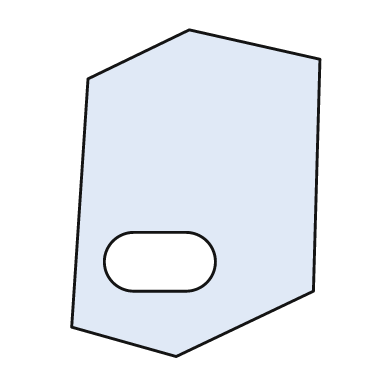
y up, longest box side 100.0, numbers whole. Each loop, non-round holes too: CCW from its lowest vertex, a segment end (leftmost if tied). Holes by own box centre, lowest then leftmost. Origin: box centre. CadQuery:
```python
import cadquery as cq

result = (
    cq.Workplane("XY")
    .moveTo(-6.0, -50.0)
    .lineTo(36.0, -30.0)
    .lineTo(38.0, 41.0)
    .lineTo(-2.0, 50.0)
    .lineTo(-33.0, 35.0)
    .lineTo(-38.0, -41.0)
    .close()
    .moveTo(-19.0, -30.0)
    .lineTo(-3.0, -30.0)
    .threePointArc((6.0, -21.0), (-3.0, -12.0))
    .lineTo(-19.0, -12.0)
    .threePointArc((-28.0, -21.0), (-19.0, -30.0))
    .close()
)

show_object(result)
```